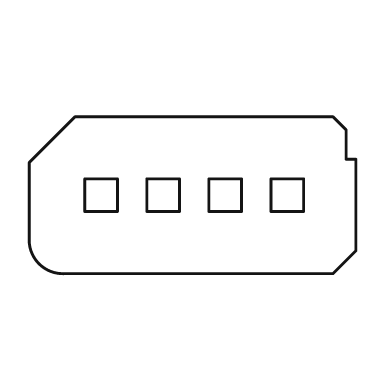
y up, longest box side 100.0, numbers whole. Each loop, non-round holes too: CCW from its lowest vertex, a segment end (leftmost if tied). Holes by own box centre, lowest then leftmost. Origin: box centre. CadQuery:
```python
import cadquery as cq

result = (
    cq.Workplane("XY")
    .moveTo(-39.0, -24.0)
    .lineTo(43.0, -24.0)
    .lineTo(50.0, -17.0)
    .lineTo(50.0, 11.0)
    .lineTo(47.0, 11.0)
    .lineTo(47.0, 20.0)
    .lineTo(43.0, 24.0)
    .lineTo(-36.0, 24.0)
    .lineTo(-50.0, 10.0)
    .lineTo(-50.0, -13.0)
    .threePointArc((-47.0, -21.0), (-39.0, -24.0))
    .close()
    .moveTo(-33.0, -5.0)
    .lineTo(-23.0, -5.0)
    .lineTo(-23.0, 5.0)
    .lineTo(-33.0, 5.0)
    .close()
    .moveTo(-14.0, -5.0)
    .lineTo(-4.0, -5.0)
    .lineTo(-4.0, 5.0)
    .lineTo(-14.0, 5.0)
    .close()
    .moveTo(5.0, -5.0)
    .lineTo(15.0, -5.0)
    .lineTo(15.0, 5.0)
    .lineTo(5.0, 5.0)
    .close()
    .moveTo(24.0, -5.0)
    .lineTo(34.0, -5.0)
    .lineTo(34.0, 5.0)
    .lineTo(24.0, 5.0)
    .close()
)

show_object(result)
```